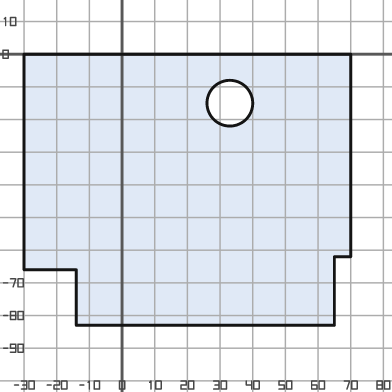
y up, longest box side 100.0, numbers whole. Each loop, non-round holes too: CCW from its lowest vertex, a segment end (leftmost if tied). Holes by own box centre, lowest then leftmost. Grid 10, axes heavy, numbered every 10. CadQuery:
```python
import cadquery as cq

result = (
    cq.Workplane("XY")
    .moveTo(-14.0, -83.0)
    .lineTo(65.0, -83.0)
    .lineTo(65.0, -62.0)
    .lineTo(70.0, -62.0)
    .lineTo(70.0, 0.0)
    .lineTo(-30.0, 0.0)
    .lineTo(-30.0, -66.0)
    .lineTo(-14.0, -66.0)
    .close()
    .moveTo(33.0, -15.0)
    .circle(7.0)
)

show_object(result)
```